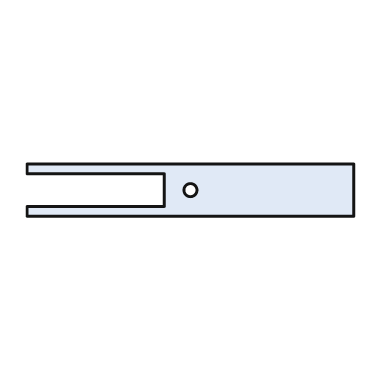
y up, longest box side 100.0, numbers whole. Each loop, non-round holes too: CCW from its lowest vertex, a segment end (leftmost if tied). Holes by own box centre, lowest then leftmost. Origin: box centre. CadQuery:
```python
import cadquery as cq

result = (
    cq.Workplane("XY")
    .moveTo(-50.0, -8.0)
    .lineTo(50.0, -8.0)
    .lineTo(50.0, 8.0)
    .lineTo(-50.0, 8.0)
    .lineTo(-50.0, 5.0)
    .lineTo(-8.0, 5.0)
    .lineTo(-8.0, -5.0)
    .lineTo(-50.0, -5.0)
    .close()
    .moveTo(0.0, 0.0)
    .circle(2.0)
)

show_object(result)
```